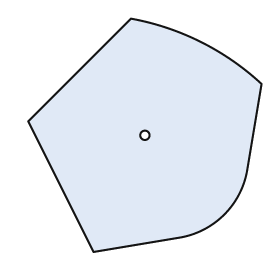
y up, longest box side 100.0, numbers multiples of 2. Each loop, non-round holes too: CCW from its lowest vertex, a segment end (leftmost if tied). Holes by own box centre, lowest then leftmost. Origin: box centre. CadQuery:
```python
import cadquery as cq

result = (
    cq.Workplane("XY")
    .moveTo(-22.0, -50.0)
    .lineTo(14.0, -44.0)
    .threePointArc((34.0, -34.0), (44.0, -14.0))
    .lineTo(50.0, 22.0)
    .threePointArc((24.0, 40.0), (-6.0, 50.0))
    .lineTo(-50.0, 6.0)
    .close()
    .moveTo(0.0, 0.0)
    .circle(2.0)
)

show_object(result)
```